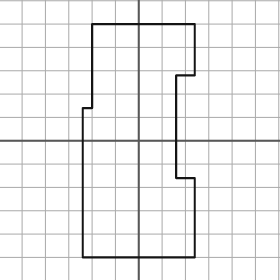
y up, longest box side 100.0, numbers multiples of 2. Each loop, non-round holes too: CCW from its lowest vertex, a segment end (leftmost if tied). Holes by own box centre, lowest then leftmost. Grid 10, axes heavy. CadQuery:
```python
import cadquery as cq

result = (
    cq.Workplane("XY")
    .moveTo(-24.0, -50.0)
    .lineTo(24.0, -50.0)
    .lineTo(24.0, -16.0)
    .lineTo(16.0, -16.0)
    .lineTo(16.0, 28.0)
    .lineTo(24.0, 28.0)
    .lineTo(24.0, 50.0)
    .lineTo(-20.0, 50.0)
    .lineTo(-20.0, 14.0)
    .lineTo(-24.0, 14.0)
    .close()
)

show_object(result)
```